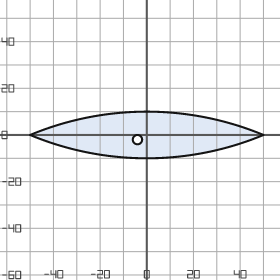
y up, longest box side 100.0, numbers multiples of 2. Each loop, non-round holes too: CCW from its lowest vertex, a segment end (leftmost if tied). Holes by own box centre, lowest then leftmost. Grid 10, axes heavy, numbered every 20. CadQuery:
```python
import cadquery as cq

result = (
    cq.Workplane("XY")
    .moveTo(-50.0, 0.0)
    .threePointArc((0.0, -10.0), (50.0, 0.0))
    .threePointArc((0.0, 10.0), (-50.0, 0.0))
    .close()
    .moveTo(-4.0, -2.0)
    .circle(2.0)
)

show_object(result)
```